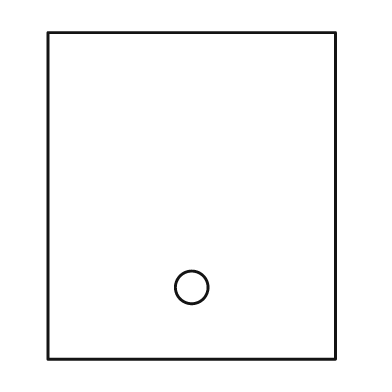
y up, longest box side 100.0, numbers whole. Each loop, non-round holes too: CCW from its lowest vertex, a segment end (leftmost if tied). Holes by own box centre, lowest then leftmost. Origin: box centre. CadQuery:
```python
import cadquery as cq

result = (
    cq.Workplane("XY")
    .moveTo(-44.0, -50.0)
    .lineTo(44.0, -50.0)
    .lineTo(44.0, 50.0)
    .lineTo(-44.0, 50.0)
    .close()
    .moveTo(0.0, -28.0)
    .circle(5.0)
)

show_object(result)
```